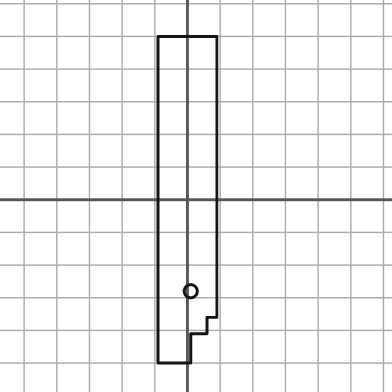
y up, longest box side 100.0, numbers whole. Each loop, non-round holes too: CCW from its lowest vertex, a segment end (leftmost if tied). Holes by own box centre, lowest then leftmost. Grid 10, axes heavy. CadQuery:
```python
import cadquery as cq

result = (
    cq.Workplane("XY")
    .moveTo(-9.0, -50.0)
    .lineTo(1.0, -50.0)
    .lineTo(1.0, -41.0)
    .lineTo(6.0, -41.0)
    .lineTo(6.0, -36.0)
    .lineTo(9.0, -36.0)
    .lineTo(9.0, 50.0)
    .lineTo(-9.0, 50.0)
    .close()
    .moveTo(1.0, -28.0)
    .circle(2.0)
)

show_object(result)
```